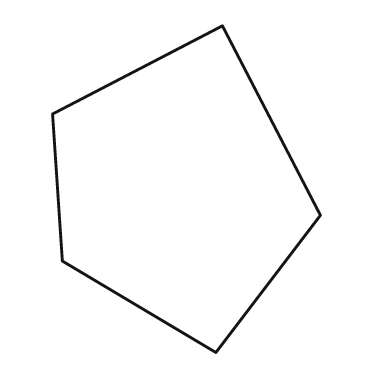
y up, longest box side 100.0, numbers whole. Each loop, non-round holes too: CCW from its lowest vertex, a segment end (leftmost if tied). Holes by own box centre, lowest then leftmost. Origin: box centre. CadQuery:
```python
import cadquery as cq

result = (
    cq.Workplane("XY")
    .moveTo(9.0, -50.0)
    .lineTo(41.0, -8.0)
    .lineTo(11.0, 50.0)
    .lineTo(-41.0, 23.0)
    .lineTo(-38.0, -22.0)
    .close()
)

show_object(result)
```